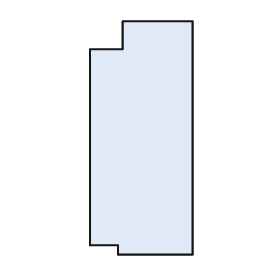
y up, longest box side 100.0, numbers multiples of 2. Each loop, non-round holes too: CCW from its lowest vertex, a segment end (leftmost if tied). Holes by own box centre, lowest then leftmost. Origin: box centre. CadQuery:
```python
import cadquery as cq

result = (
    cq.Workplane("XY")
    .moveTo(-10.0, -50.0)
    .lineTo(22.0, -50.0)
    .lineTo(22.0, 50.0)
    .lineTo(-8.0, 50.0)
    .lineTo(-8.0, 38.0)
    .lineTo(-22.0, 38.0)
    .lineTo(-22.0, -46.0)
    .lineTo(-10.0, -46.0)
    .close()
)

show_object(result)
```